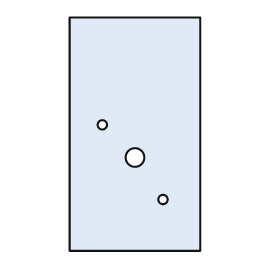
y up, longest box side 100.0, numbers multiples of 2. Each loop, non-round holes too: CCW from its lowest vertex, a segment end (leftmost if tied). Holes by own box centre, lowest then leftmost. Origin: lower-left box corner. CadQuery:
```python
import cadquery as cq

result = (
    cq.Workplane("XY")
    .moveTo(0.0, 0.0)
    .lineTo(56.0, 0.0)
    .lineTo(56.0, 100.0)
    .lineTo(0.0, 100.0)
    .close()
    .moveTo(40.0, 22.0)
    .circle(2.0)
    .moveTo(28.0, 40.0)
    .circle(4.0)
    .moveTo(14.0, 54.0)
    .circle(2.0)
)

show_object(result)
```